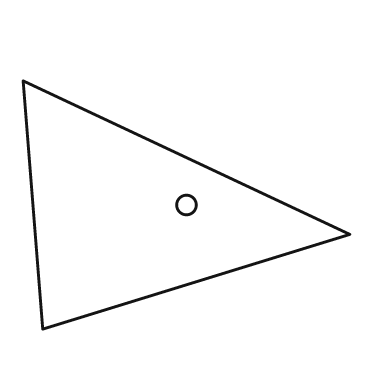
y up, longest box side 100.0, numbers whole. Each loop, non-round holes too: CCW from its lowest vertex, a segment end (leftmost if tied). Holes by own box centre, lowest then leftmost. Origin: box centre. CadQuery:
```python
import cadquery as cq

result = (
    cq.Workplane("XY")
    .moveTo(-44.0, -38.0)
    .lineTo(50.0, -9.0)
    .lineTo(-50.0, 38.0)
    .close()
    .moveTo(0.0, 0.0)
    .circle(3.0)
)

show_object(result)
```